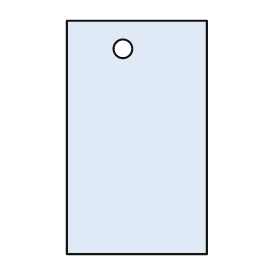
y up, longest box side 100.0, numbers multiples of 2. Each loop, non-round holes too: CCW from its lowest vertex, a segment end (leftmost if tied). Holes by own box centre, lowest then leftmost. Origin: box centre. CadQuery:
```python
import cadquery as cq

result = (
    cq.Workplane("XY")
    .moveTo(-30.0, -50.0)
    .lineTo(30.0, -50.0)
    .lineTo(30.0, 50.0)
    .lineTo(-30.0, 50.0)
    .close()
    .moveTo(-6.0, 38.0)
    .circle(4.0)
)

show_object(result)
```